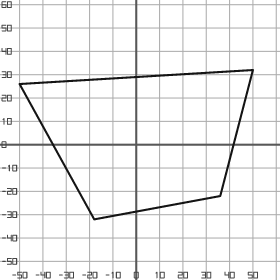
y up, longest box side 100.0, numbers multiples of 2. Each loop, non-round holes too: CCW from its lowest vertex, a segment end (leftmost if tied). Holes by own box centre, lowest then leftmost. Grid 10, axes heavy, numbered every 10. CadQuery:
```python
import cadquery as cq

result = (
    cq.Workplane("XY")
    .moveTo(-18.0, -32.0)
    .lineTo(36.0, -22.0)
    .lineTo(50.0, 32.0)
    .lineTo(-50.0, 26.0)
    .close()
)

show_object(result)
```